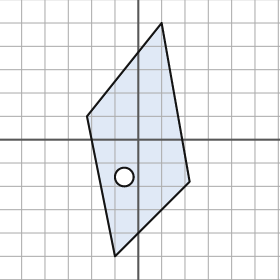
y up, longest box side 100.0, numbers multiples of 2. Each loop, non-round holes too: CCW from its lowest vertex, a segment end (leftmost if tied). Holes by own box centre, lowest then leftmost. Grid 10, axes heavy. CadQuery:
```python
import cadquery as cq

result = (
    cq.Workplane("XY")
    .moveTo(-10.0, -50.0)
    .lineTo(22.0, -18.0)
    .lineTo(10.0, 50.0)
    .lineTo(-22.0, 10.0)
    .close()
    .moveTo(-6.0, -16.0)
    .circle(4.0)
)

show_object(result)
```